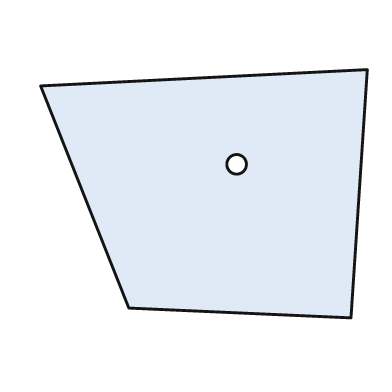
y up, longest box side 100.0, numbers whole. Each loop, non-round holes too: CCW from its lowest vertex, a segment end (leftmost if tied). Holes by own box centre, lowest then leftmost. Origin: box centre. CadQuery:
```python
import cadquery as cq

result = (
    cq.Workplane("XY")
    .moveTo(45.0, -38.0)
    .lineTo(50.0, 38.0)
    .lineTo(-50.0, 33.0)
    .lineTo(-23.0, -35.0)
    .close()
    .moveTo(10.0, 9.0)
    .circle(3.0)
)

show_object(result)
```